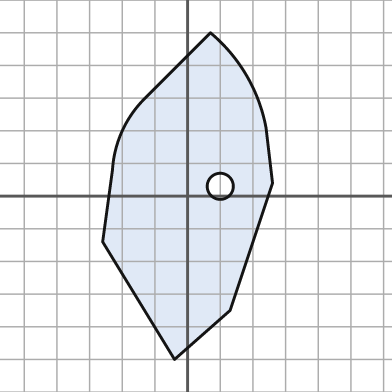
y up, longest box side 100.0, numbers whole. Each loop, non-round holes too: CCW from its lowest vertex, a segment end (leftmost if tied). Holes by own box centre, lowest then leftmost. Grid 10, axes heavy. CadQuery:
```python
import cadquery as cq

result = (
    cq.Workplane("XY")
    .moveTo(-4.0, -50.0)
    .lineTo(13.0, -35.0)
    .lineTo(26.0, 4.0)
    .lineTo(24.0, 21.0)
    .threePointArc((18.0, 37.0), (7.0, 50.0))
    .lineTo(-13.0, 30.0)
    .threePointArc((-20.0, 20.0), (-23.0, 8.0))
    .lineTo(-26.0, -14.0)
    .close()
    .moveTo(10.0, 3.0)
    .circle(4.0)
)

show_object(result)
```